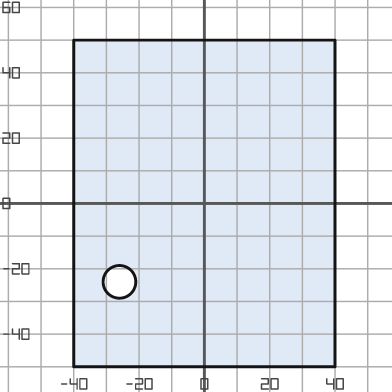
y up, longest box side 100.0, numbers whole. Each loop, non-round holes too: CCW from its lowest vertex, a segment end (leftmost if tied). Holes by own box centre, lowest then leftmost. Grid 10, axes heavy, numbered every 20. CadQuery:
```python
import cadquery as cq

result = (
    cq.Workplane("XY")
    .moveTo(-40.0, -50.0)
    .lineTo(40.0, -50.0)
    .lineTo(40.0, 50.0)
    .lineTo(-40.0, 50.0)
    .close()
    .moveTo(-26.0, -24.0)
    .circle(5.0)
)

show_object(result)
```